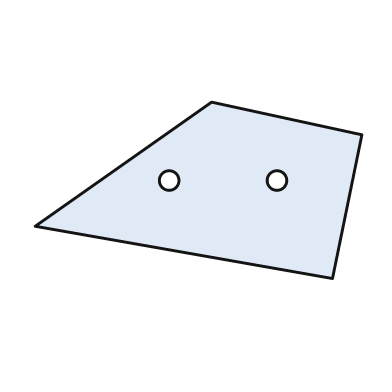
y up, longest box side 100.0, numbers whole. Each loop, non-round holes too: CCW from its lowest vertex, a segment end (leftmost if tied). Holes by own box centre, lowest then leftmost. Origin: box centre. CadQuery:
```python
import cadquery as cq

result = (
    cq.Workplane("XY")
    .moveTo(41.0, -27.0)
    .lineTo(50.0, 17.0)
    .lineTo(4.0, 27.0)
    .lineTo(-50.0, -11.0)
    .close()
    .moveTo(-9.0, 3.0)
    .circle(3.0)
    .moveTo(24.0, 3.0)
    .circle(3.0)
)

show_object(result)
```